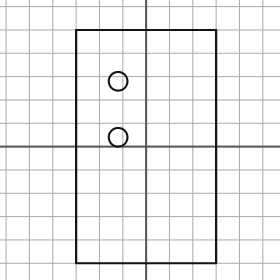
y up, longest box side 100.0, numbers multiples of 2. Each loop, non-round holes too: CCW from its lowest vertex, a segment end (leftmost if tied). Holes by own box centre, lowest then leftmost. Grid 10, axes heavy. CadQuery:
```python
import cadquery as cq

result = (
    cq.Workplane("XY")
    .moveTo(-30.0, -50.0)
    .lineTo(30.0, -50.0)
    .lineTo(30.0, 50.0)
    .lineTo(-30.0, 50.0)
    .close()
    .moveTo(-12.0, 4.0)
    .circle(4.0)
    .moveTo(-12.0, 28.0)
    .circle(4.0)
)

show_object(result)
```